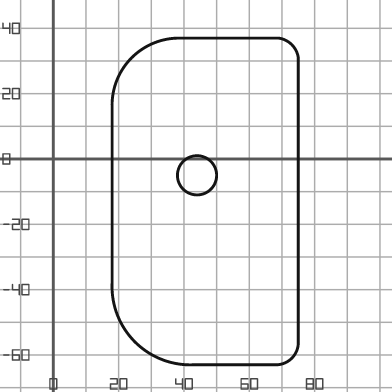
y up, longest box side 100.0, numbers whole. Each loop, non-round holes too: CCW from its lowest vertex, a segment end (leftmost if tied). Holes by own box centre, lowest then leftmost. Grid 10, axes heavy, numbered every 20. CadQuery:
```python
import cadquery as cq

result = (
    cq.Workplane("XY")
    .moveTo(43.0, -63.0)
    .lineTo(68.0, -63.0)
    .threePointArc((73.0, -61.0), (75.0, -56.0))
    .lineTo(75.0, 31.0)
    .threePointArc((73.0, 35.0), (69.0, 37.0))
    .lineTo(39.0, 37.0)
    .threePointArc((24.0, 31.0), (18.0, 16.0))
    .lineTo(18.0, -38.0)
    .threePointArc((25.0, -56.0), (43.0, -63.0))
    .close()
    .moveTo(44.0, -5.0)
    .circle(6.0)
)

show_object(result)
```